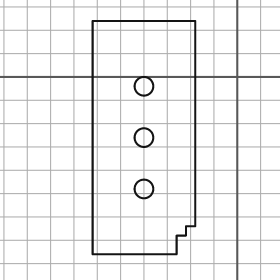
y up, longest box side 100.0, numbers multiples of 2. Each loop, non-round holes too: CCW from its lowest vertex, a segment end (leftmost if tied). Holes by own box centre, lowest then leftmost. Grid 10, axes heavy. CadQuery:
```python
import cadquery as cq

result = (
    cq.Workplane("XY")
    .moveTo(-62.0, -76.0)
    .lineTo(-26.0, -76.0)
    .lineTo(-26.0, -68.0)
    .lineTo(-22.0, -68.0)
    .lineTo(-22.0, -64.0)
    .lineTo(-18.0, -64.0)
    .lineTo(-18.0, 24.0)
    .lineTo(-62.0, 24.0)
    .close()
    .moveTo(-40.0, -48.0)
    .circle(4.0)
    .moveTo(-40.0, -26.0)
    .circle(4.0)
    .moveTo(-40.0, -4.0)
    .circle(4.0)
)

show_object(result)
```